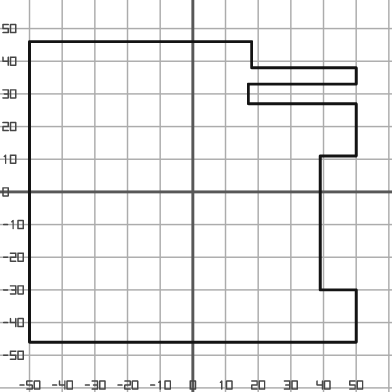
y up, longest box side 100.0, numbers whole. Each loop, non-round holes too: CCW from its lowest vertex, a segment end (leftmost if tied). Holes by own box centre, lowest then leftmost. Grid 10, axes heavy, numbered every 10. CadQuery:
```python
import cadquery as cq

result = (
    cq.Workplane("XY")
    .moveTo(-50.0, -46.0)
    .lineTo(50.0, -46.0)
    .lineTo(50.0, -30.0)
    .lineTo(39.0, -30.0)
    .lineTo(39.0, 11.0)
    .lineTo(50.0, 11.0)
    .lineTo(50.0, 27.0)
    .lineTo(17.0, 27.0)
    .lineTo(17.0, 33.0)
    .lineTo(50.0, 33.0)
    .lineTo(50.0, 38.0)
    .lineTo(18.0, 38.0)
    .lineTo(18.0, 46.0)
    .lineTo(-50.0, 46.0)
    .close()
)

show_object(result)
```